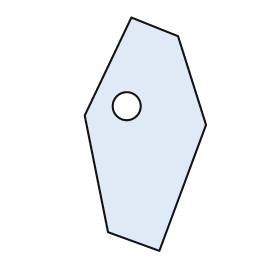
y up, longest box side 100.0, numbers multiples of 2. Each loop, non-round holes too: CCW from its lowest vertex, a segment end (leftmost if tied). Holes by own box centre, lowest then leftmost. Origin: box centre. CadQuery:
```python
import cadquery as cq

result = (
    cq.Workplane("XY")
    .moveTo(6.0, -50.0)
    .lineTo(26.0, 4.0)
    .lineTo(14.0, 42.0)
    .lineTo(-6.0, 50.0)
    .lineTo(-26.0, 8.0)
    .lineTo(-16.0, -42.0)
    .close()
    .moveTo(-8.0, 12.0)
    .circle(6.0)
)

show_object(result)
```